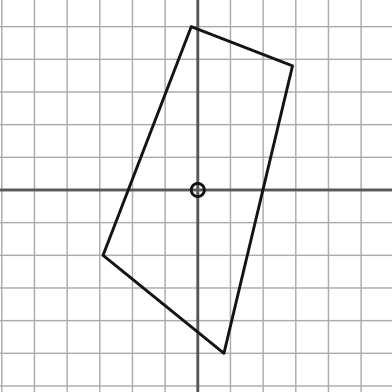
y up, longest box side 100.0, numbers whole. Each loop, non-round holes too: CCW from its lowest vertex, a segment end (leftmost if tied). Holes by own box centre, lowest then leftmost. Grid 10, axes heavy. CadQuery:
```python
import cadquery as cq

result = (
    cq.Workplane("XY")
    .moveTo(8.0, -50.0)
    .lineTo(29.0, 38.0)
    .lineTo(-2.0, 50.0)
    .lineTo(-29.0, -20.0)
    .close()
    .moveTo(0.0, 0.0)
    .circle(2.0)
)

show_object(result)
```